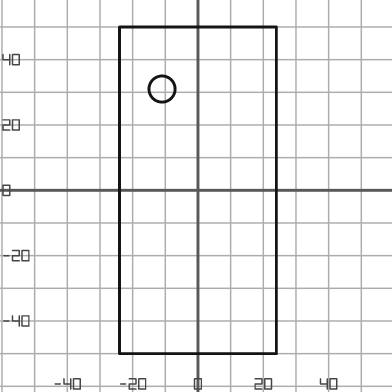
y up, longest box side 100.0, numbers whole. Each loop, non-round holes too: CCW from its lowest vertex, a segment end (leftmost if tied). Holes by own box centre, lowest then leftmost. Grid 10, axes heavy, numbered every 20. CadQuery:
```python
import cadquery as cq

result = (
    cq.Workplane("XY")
    .moveTo(-24.0, -50.0)
    .lineTo(24.0, -50.0)
    .lineTo(24.0, 50.0)
    .lineTo(-24.0, 50.0)
    .close()
    .moveTo(-11.0, 31.0)
    .circle(4.0)
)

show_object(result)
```